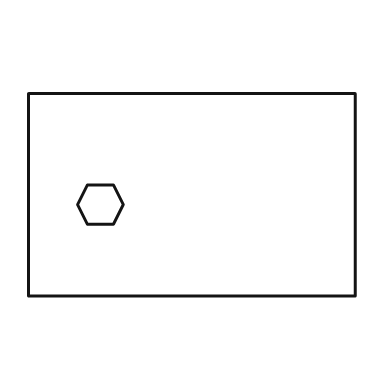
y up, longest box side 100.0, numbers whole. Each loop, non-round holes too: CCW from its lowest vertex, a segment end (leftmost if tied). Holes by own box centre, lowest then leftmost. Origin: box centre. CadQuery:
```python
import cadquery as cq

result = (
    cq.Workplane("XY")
    .moveTo(-50.0, -31.0)
    .lineTo(50.0, -31.0)
    .lineTo(50.0, 31.0)
    .lineTo(-50.0, 31.0)
    .close()
    .moveTo(-32.0, -9.0)
    .lineTo(-24.0, -9.0)
    .lineTo(-21.0, -3.0)
    .lineTo(-24.0, 3.0)
    .lineTo(-32.0, 3.0)
    .lineTo(-35.0, -3.0)
    .close()
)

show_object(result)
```